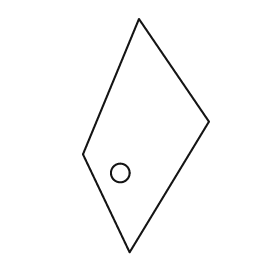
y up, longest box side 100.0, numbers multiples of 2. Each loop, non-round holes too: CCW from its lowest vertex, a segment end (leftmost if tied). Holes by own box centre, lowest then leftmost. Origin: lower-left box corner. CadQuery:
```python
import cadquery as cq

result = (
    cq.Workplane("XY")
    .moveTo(20.0, 0.0)
    .lineTo(54.0, 56.0)
    .lineTo(24.0, 100.0)
    .lineTo(0.0, 42.0)
    .close()
    .moveTo(16.0, 34.0)
    .circle(4.0)
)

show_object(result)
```